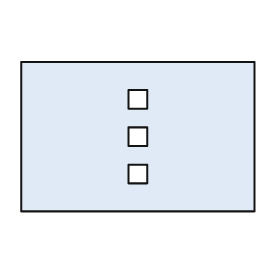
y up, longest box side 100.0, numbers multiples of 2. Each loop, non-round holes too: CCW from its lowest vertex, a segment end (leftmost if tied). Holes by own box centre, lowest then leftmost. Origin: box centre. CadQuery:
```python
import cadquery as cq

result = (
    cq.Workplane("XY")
    .moveTo(-50.0, -32.0)
    .lineTo(50.0, -32.0)
    .lineTo(50.0, 32.0)
    .lineTo(-50.0, 32.0)
    .close()
    .moveTo(-4.0, -20.0)
    .lineTo(4.0, -20.0)
    .lineTo(4.0, -12.0)
    .lineTo(-4.0, -12.0)
    .close()
    .moveTo(-4.0, -4.0)
    .lineTo(4.0, -4.0)
    .lineTo(4.0, 4.0)
    .lineTo(-4.0, 4.0)
    .close()
    .moveTo(-4.0, 12.0)
    .lineTo(4.0, 12.0)
    .lineTo(4.0, 20.0)
    .lineTo(-4.0, 20.0)
    .close()
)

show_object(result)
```